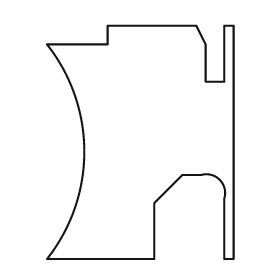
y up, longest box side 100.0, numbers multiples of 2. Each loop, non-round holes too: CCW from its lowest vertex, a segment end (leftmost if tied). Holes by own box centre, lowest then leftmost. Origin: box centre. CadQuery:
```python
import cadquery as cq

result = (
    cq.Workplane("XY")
    .moveTo(-40.0, -50.0)
    .lineTo(6.0, -50.0)
    .lineTo(6.0, -26.0)
    .lineTo(18.0, -14.0)
    .lineTo(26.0, -14.0)
    .threePointArc((34.0, -16.0), (36.0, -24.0))
    .lineTo(36.0, -50.0)
    .lineTo(40.0, -50.0)
    .lineTo(40.0, 50.0)
    .lineTo(36.0, 50.0)
    .lineTo(36.0, 26.0)
    .lineTo(28.0, 26.0)
    .lineTo(28.0, 42.0)
    .lineTo(24.0, 50.0)
    .lineTo(-14.0, 50.0)
    .lineTo(-14.0, 42.0)
    .lineTo(-40.0, 42.0)
    .threePointArc((-24.0, -4.0), (-40.0, -50.0))
    .close()
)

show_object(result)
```